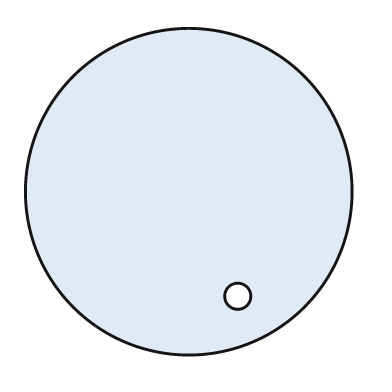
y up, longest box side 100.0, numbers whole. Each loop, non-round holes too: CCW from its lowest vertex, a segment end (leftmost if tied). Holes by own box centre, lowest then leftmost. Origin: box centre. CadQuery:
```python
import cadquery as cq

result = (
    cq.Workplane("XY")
    .moveTo(0.0, 0.0)
    .circle(50.0)
    .moveTo(15.0, -32.0)
    .circle(4.0)
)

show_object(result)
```